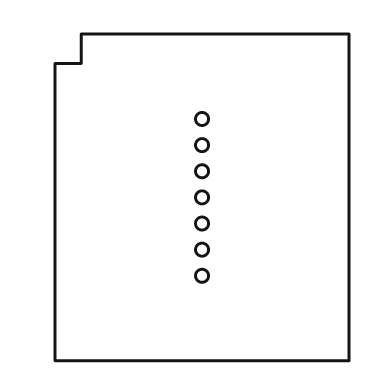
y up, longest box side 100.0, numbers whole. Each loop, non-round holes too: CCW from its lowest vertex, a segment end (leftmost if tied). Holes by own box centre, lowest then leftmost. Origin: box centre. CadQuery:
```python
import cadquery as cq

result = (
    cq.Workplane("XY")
    .moveTo(-45.0, -50.0)
    .lineTo(45.0, -50.0)
    .lineTo(45.0, 50.0)
    .lineTo(-37.0, 50.0)
    .lineTo(-37.0, 41.0)
    .lineTo(-45.0, 41.0)
    .close()
    .moveTo(0.0, -24.0)
    .circle(2.0)
    .moveTo(0.0, -16.0)
    .circle(2.0)
    .moveTo(0.0, -8.0)
    .circle(2.0)
    .moveTo(0.0, 0.0)
    .circle(2.0)
    .moveTo(0.0, 8.0)
    .circle(2.0)
    .moveTo(0.0, 16.0)
    .circle(2.0)
    .moveTo(0.0, 24.0)
    .circle(2.0)
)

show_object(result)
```